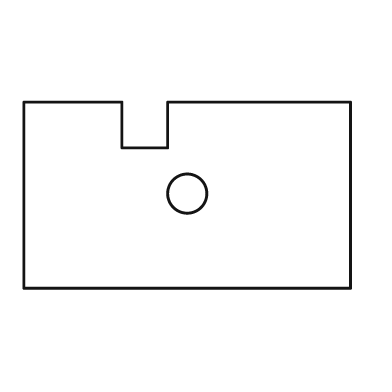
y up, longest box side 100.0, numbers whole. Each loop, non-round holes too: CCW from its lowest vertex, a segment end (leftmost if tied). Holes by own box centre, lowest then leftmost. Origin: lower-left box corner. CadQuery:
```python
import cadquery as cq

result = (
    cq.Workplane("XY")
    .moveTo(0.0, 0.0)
    .lineTo(100.0, 0.0)
    .lineTo(100.0, 57.0)
    .lineTo(44.0, 57.0)
    .lineTo(44.0, 43.0)
    .lineTo(30.0, 43.0)
    .lineTo(30.0, 57.0)
    .lineTo(0.0, 57.0)
    .close()
    .moveTo(50.0, 29.0)
    .circle(6.0)
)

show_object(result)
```